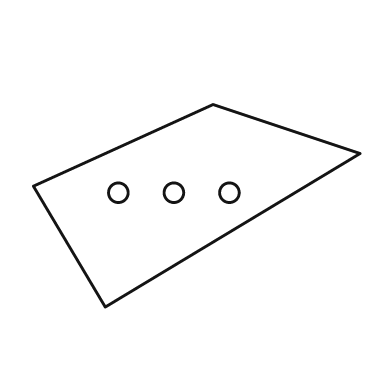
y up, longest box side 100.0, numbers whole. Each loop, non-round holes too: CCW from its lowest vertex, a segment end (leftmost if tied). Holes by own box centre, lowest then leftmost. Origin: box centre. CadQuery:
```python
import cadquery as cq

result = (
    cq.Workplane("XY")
    .moveTo(-28.0, -31.0)
    .lineTo(50.0, 16.0)
    .lineTo(5.0, 31.0)
    .lineTo(-50.0, 6.0)
    .close()
    .moveTo(-24.0, 4.0)
    .circle(3.0)
    .moveTo(-7.0, 4.0)
    .circle(3.0)
    .moveTo(10.0, 4.0)
    .circle(3.0)
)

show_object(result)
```